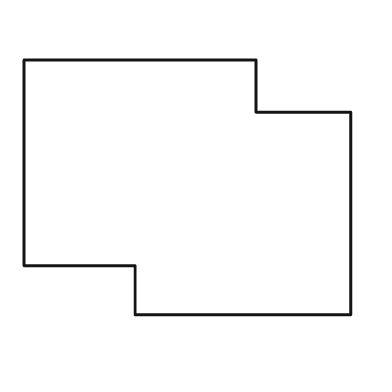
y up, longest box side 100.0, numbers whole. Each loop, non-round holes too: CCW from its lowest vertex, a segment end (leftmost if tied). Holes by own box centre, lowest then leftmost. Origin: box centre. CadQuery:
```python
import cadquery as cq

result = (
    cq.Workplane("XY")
    .moveTo(-16.0, -39.0)
    .lineTo(50.0, -39.0)
    .lineTo(50.0, 23.0)
    .lineTo(21.0, 23.0)
    .lineTo(21.0, 39.0)
    .lineTo(-50.0, 39.0)
    .lineTo(-50.0, -24.0)
    .lineTo(-16.0, -24.0)
    .close()
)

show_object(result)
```